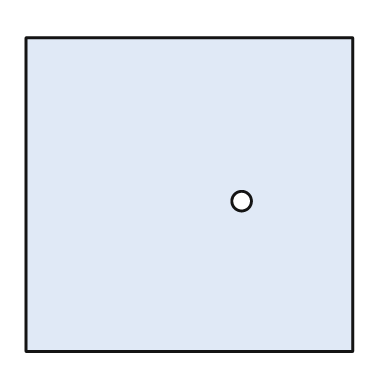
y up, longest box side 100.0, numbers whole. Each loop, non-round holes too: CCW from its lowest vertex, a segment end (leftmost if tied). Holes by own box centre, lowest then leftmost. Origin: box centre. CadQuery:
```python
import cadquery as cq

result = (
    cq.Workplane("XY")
    .moveTo(-50.0, -48.0)
    .lineTo(50.0, -48.0)
    .lineTo(50.0, 48.0)
    .lineTo(-50.0, 48.0)
    .close()
    .moveTo(16.0, -2.0)
    .circle(3.0)
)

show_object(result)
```